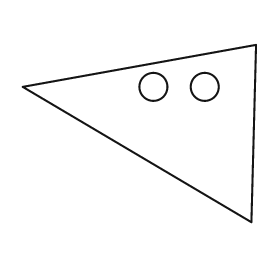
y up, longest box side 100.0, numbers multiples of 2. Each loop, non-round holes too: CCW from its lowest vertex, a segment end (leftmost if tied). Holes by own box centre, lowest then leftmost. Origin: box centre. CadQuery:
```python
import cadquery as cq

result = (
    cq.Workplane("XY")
    .moveTo(48.0, -38.0)
    .lineTo(50.0, 38.0)
    .lineTo(-50.0, 20.0)
    .close()
    .moveTo(6.0, 20.0)
    .circle(6.0)
    .moveTo(28.0, 20.0)
    .circle(6.0)
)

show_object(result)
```